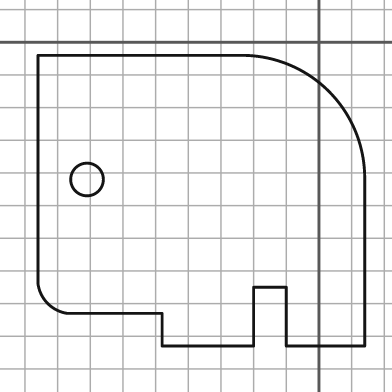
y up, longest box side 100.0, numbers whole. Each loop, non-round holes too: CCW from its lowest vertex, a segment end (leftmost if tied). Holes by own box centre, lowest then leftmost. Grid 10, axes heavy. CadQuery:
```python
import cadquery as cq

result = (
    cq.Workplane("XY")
    .moveTo(-48.0, -93.0)
    .lineTo(-20.0, -93.0)
    .lineTo(-20.0, -75.0)
    .lineTo(-10.0, -75.0)
    .lineTo(-10.0, -93.0)
    .lineTo(14.0, -93.0)
    .lineTo(14.0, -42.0)
    .threePointArc((3.0, -15.0), (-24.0, -4.0))
    .lineTo(-86.0, -4.0)
    .lineTo(-86.0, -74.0)
    .threePointArc((-83.0, -80.0), (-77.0, -83.0))
    .lineTo(-48.0, -83.0)
    .close()
    .moveTo(-71.0, -42.0)
    .circle(5.0)
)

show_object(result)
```